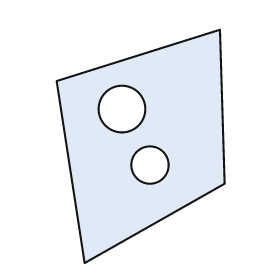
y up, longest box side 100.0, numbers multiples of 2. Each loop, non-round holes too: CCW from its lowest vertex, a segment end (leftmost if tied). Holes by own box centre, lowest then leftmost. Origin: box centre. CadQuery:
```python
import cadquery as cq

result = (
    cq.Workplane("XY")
    .moveTo(-24.0, -50.0)
    .lineTo(36.0, -16.0)
    .lineTo(34.0, 50.0)
    .lineTo(-36.0, 28.0)
    .close()
    .moveTo(4.0, -8.0)
    .circle(8.0)
    .moveTo(-8.0, 16.0)
    .circle(10.0)
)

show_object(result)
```